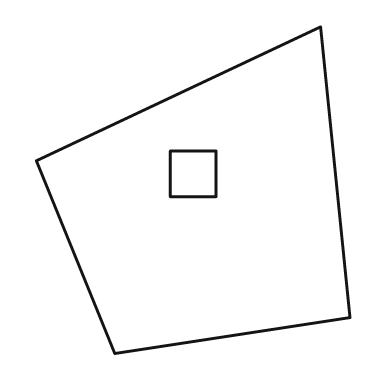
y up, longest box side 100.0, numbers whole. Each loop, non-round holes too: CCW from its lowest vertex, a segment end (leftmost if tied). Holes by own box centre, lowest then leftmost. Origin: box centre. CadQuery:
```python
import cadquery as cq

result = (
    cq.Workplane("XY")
    .moveTo(-24.0, -50.0)
    .lineTo(48.0, -39.0)
    .lineTo(39.0, 50.0)
    .lineTo(-48.0, 9.0)
    .close()
    .moveTo(-7.0, -2.0)
    .lineTo(7.0, -2.0)
    .lineTo(7.0, 12.0)
    .lineTo(-7.0, 12.0)
    .close()
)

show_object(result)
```